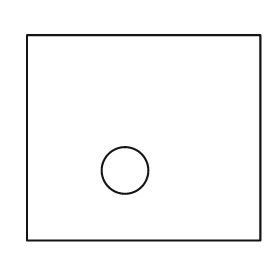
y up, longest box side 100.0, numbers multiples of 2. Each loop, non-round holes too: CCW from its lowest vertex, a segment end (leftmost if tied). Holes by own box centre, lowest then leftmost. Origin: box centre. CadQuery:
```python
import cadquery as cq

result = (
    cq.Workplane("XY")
    .moveTo(-50.0, -44.0)
    .lineTo(50.0, -44.0)
    .lineTo(50.0, 44.0)
    .lineTo(-50.0, 44.0)
    .close()
    .moveTo(-8.0, -14.0)
    .circle(10.0)
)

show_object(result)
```